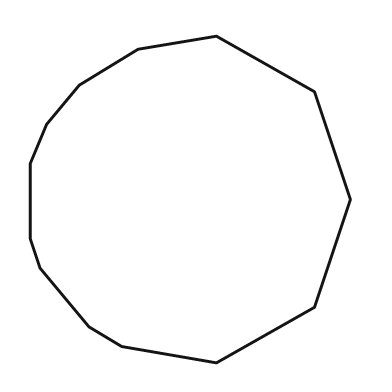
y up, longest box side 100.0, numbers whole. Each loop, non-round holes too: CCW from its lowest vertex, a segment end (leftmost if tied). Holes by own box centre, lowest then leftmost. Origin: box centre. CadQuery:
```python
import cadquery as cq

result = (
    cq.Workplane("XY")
    .moveTo(8.0, -50.0)
    .lineTo(38.0, -33.0)
    .lineTo(49.0, 0.0)
    .lineTo(38.0, 33.0)
    .lineTo(8.0, 50.0)
    .lineTo(-16.0, 46.0)
    .lineTo(-34.0, 35.0)
    .lineTo(-44.0, 23.0)
    .lineTo(-49.0, 11.0)
    .lineTo(-49.0, -12.0)
    .lineTo(-46.0, -21.0)
    .lineTo(-31.0, -39.0)
    .lineTo(-21.0, -45.0)
    .close()
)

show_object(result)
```